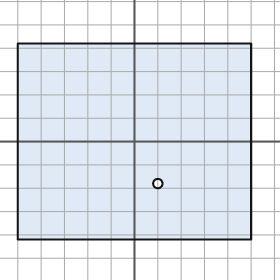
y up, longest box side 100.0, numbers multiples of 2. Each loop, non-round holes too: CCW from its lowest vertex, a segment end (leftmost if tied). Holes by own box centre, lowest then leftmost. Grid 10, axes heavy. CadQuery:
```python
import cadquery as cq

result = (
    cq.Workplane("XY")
    .moveTo(-50.0, -42.0)
    .lineTo(50.0, -42.0)
    .lineTo(50.0, 42.0)
    .lineTo(-50.0, 42.0)
    .close()
    .moveTo(10.0, -18.0)
    .circle(2.0)
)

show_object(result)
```